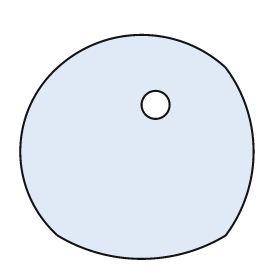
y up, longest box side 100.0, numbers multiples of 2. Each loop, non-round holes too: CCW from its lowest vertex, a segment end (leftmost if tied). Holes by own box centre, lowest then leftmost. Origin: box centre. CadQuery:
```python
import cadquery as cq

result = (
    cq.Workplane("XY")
    .moveTo(-34.0, -38.0)
    .threePointArc((2.0, -48.0), (38.0, -38.0))
    .threePointArc((50.0, -2.0), (38.0, 34.0))
    .threePointArc((2.0, 48.0), (-34.0, 34.0))
    .threePointArc((-50.0, -2.0), (-34.0, -38.0))
    .close()
    .moveTo(8.0, 18.0)
    .circle(6.0)
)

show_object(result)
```